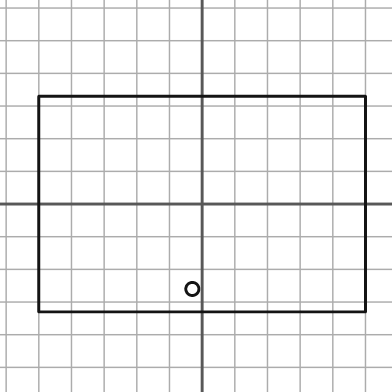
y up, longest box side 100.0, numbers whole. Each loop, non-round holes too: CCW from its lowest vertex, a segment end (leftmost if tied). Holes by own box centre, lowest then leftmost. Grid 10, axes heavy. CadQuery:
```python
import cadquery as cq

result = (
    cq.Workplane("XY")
    .moveTo(-50.0, -33.0)
    .lineTo(50.0, -33.0)
    .lineTo(50.0, 33.0)
    .lineTo(-50.0, 33.0)
    .close()
    .moveTo(-3.0, -26.0)
    .circle(2.0)
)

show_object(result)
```